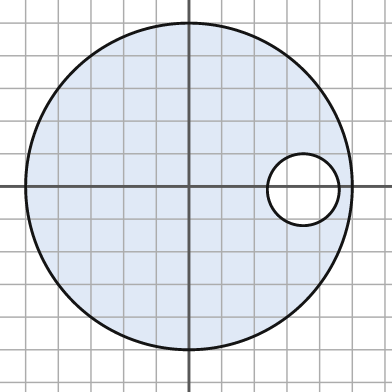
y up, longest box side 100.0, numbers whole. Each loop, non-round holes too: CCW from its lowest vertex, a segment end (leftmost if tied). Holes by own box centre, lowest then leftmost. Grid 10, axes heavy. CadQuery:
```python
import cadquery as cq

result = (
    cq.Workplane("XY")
    .moveTo(0.0, 0.0)
    .circle(50.0)
    .moveTo(35.0, -1.0)
    .circle(11.0)
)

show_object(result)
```